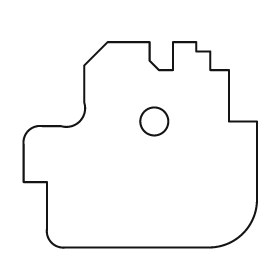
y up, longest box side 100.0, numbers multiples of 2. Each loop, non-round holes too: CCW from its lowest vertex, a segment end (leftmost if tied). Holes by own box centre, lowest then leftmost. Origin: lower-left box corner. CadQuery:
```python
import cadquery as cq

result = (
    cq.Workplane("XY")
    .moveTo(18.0, 0.0)
    .lineTo(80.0, 0.0)
    .threePointArc((94.0, 6.0), (100.0, 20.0))
    .lineTo(100.0, 54.0)
    .lineTo(88.0, 54.0)
    .lineTo(88.0, 76.0)
    .lineTo(80.0, 76.0)
    .lineTo(80.0, 84.0)
    .lineTo(74.0, 84.0)
    .lineTo(74.0, 88.0)
    .lineTo(64.0, 88.0)
    .lineTo(64.0, 76.0)
    .lineTo(58.0, 76.0)
    .lineTo(54.0, 80.0)
    .lineTo(54.0, 88.0)
    .lineTo(36.0, 88.0)
    .lineTo(26.0, 78.0)
    .lineTo(26.0, 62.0)
    .threePointArc((24.0, 54.0), (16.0, 52.0))
    .lineTo(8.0, 52.0)
    .threePointArc((2.0, 50.0), (0.0, 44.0))
    .lineTo(0.0, 28.0)
    .lineTo(10.0, 28.0)
    .lineTo(10.0, 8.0)
    .threePointArc((12.0, 2.0), (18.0, 0.0))
    .close()
    .moveTo(56.0, 54.0)
    .circle(6.0)
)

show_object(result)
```